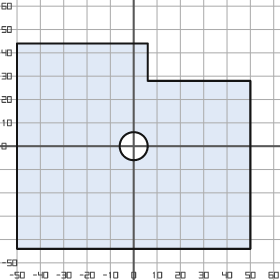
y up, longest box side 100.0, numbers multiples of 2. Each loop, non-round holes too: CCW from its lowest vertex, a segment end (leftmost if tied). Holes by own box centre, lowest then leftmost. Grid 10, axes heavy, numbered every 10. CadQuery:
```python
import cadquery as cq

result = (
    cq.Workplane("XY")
    .moveTo(-50.0, -44.0)
    .lineTo(50.0, -44.0)
    .lineTo(50.0, 28.0)
    .lineTo(6.0, 28.0)
    .lineTo(6.0, 44.0)
    .lineTo(-50.0, 44.0)
    .close()
    .moveTo(0.0, 0.0)
    .circle(6.0)
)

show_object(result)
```